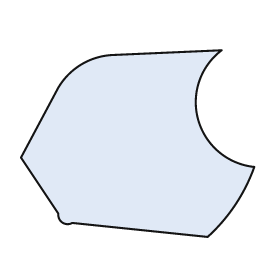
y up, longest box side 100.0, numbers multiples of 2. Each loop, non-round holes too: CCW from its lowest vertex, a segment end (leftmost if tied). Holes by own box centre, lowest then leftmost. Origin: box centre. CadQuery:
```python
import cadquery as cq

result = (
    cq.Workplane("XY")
    .moveTo(30.0, -40.0)
    .threePointArc((42.0, -26.0), (50.0, -10.0))
    .threePointArc((26.0, 10.0), (36.0, 40.0))
    .lineTo(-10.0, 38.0)
    .threePointArc((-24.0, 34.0), (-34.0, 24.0))
    .lineTo(-50.0, -6.0)
    .lineTo(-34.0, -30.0)
    .threePointArc((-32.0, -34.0), (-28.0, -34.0))
    .close()
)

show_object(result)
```